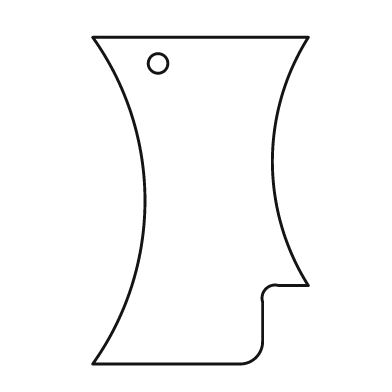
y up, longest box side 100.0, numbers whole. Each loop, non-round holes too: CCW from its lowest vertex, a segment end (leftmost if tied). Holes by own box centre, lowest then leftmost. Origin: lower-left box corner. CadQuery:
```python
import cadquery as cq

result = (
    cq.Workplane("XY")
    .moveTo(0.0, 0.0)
    .lineTo(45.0, 0.0)
    .threePointArc((50.0, 2.0), (52.0, 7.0))
    .lineTo(52.0, 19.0)
    .threePointArc((53.0, 23.0), (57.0, 24.0))
    .lineTo(66.0, 24.0)
    .threePointArc((55.0, 62.0), (66.0, 100.0))
    .lineTo(0.0, 100.0)
    .threePointArc((16.0, 50.0), (0.0, 0.0))
    .close()
    .moveTo(20.0, 92.0)
    .circle(3.0)
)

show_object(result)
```